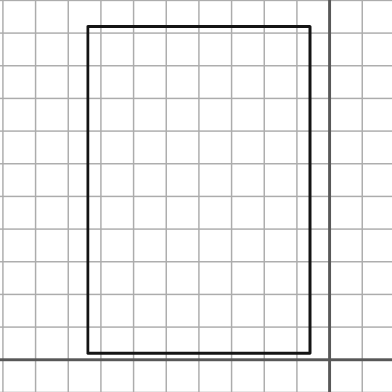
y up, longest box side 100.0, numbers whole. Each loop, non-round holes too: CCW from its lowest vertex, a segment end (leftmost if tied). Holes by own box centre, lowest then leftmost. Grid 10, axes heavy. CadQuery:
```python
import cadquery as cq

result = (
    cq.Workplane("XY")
    .moveTo(-74.0, 2.0)
    .lineTo(-6.0, 2.0)
    .lineTo(-6.0, 102.0)
    .lineTo(-74.0, 102.0)
    .close()
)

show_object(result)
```